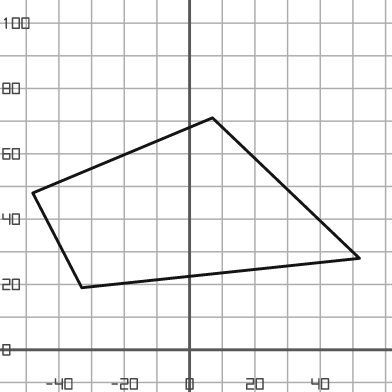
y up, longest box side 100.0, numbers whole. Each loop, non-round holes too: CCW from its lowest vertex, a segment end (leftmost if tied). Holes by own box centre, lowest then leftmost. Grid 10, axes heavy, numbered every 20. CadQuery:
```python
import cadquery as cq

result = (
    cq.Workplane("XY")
    .moveTo(-33.0, 19.0)
    .lineTo(52.0, 28.0)
    .lineTo(7.0, 71.0)
    .lineTo(-48.0, 48.0)
    .close()
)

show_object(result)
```